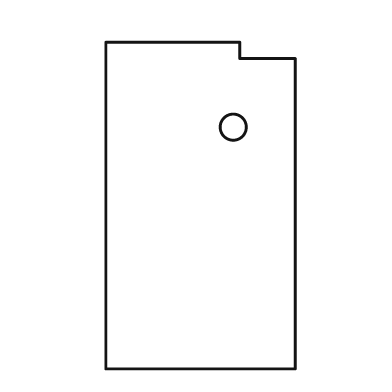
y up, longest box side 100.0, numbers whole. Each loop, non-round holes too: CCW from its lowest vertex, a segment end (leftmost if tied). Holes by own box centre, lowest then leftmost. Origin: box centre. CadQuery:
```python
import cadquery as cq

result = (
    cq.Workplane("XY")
    .moveTo(-29.0, -50.0)
    .lineTo(29.0, -50.0)
    .lineTo(29.0, 45.0)
    .lineTo(12.0, 45.0)
    .lineTo(12.0, 50.0)
    .lineTo(-29.0, 50.0)
    .close()
    .moveTo(10.0, 24.0)
    .circle(4.0)
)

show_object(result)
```